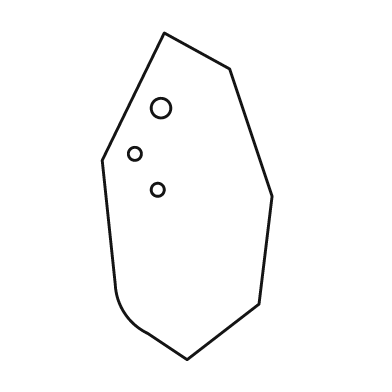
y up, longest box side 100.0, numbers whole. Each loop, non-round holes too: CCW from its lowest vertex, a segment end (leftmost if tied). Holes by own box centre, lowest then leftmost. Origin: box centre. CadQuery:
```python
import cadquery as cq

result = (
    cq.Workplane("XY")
    .moveTo(0.0, -50.0)
    .lineTo(22.0, -33.0)
    .lineTo(26.0, 0.0)
    .lineTo(13.0, 39.0)
    .lineTo(-7.0, 50.0)
    .lineTo(-26.0, 11.0)
    .lineTo(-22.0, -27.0)
    .threePointArc((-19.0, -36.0), (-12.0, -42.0))
    .close()
    .moveTo(-9.0, 2.0)
    .circle(2.0)
    .moveTo(-16.0, 13.0)
    .circle(2.0)
    .moveTo(-8.0, 27.0)
    .circle(3.0)
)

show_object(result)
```